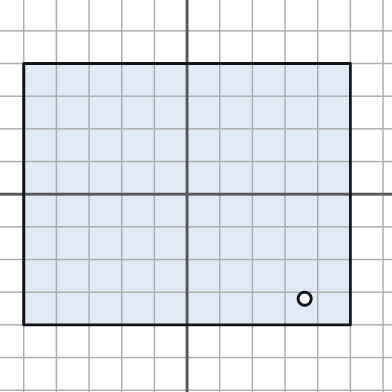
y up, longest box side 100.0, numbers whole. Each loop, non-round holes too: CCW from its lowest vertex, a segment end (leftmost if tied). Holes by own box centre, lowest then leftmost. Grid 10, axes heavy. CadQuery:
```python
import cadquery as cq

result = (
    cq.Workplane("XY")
    .moveTo(-50.0, -40.0)
    .lineTo(50.0, -40.0)
    .lineTo(50.0, 40.0)
    .lineTo(-50.0, 40.0)
    .close()
    .moveTo(36.0, -32.0)
    .circle(2.0)
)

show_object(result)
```